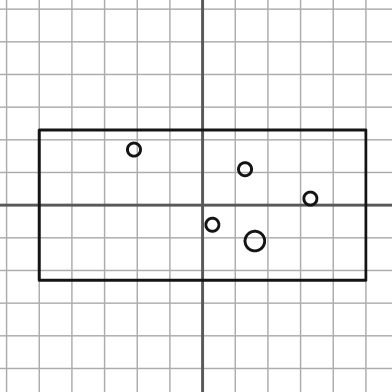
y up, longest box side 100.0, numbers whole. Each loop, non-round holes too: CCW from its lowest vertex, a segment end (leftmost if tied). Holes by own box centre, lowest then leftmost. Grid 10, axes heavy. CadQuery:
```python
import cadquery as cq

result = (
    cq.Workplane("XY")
    .moveTo(-50.0, -23.0)
    .lineTo(50.0, -23.0)
    .lineTo(50.0, 23.0)
    .lineTo(-50.0, 23.0)
    .close()
    .moveTo(16.0, -11.0)
    .circle(3.0)
    .moveTo(3.0, -6.0)
    .circle(2.0)
    .moveTo(33.0, 2.0)
    .circle(2.0)
    .moveTo(13.0, 11.0)
    .circle(2.0)
    .moveTo(-21.0, 17.0)
    .circle(2.0)
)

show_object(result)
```